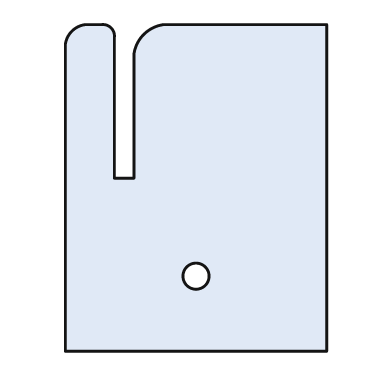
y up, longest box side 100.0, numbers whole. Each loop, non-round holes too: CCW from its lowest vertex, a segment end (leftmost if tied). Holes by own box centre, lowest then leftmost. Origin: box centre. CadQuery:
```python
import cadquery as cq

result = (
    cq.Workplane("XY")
    .moveTo(-40.0, -50.0)
    .lineTo(40.0, -50.0)
    .lineTo(40.0, 50.0)
    .lineTo(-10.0, 50.0)
    .threePointArc((-16.0, 47.0), (-19.0, 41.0))
    .lineTo(-19.0, 3.0)
    .lineTo(-25.0, 3.0)
    .lineTo(-25.0, 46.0)
    .threePointArc((-26.0, 49.0), (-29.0, 50.0))
    .lineTo(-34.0, 50.0)
    .threePointArc((-38.0, 48.0), (-40.0, 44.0))
    .close()
    .moveTo(0.0, -27.0)
    .circle(4.0)
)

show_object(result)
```